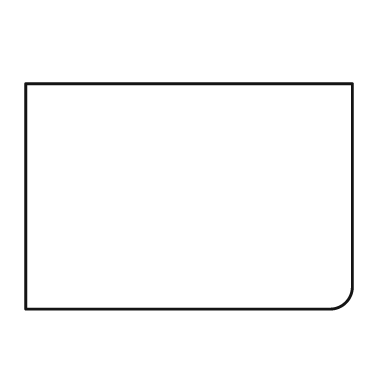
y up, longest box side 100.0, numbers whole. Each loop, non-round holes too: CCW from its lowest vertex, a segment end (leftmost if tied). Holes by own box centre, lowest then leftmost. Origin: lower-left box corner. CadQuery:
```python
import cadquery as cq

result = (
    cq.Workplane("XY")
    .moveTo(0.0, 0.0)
    .lineTo(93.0, 0.0)
    .threePointArc((98.0, 2.0), (100.0, 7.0))
    .lineTo(100.0, 69.0)
    .lineTo(0.0, 69.0)
    .close()
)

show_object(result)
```